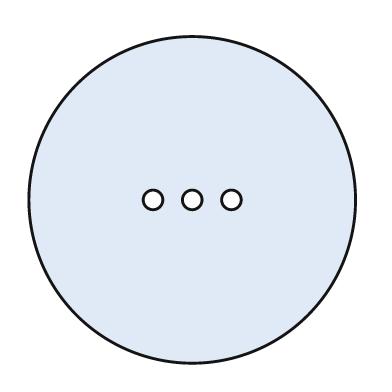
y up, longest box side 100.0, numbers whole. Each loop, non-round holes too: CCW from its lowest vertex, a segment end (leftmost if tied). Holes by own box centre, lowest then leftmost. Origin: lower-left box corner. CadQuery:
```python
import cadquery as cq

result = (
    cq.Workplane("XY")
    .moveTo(50.0, 50.0)
    .circle(50.0)
    .moveTo(38.0, 50.0)
    .circle(3.0)
    .moveTo(50.0, 50.0)
    .circle(3.0)
    .moveTo(62.0, 50.0)
    .circle(3.0)
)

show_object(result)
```